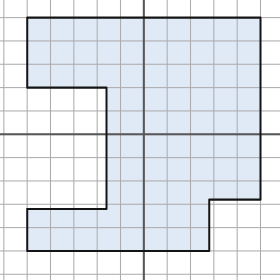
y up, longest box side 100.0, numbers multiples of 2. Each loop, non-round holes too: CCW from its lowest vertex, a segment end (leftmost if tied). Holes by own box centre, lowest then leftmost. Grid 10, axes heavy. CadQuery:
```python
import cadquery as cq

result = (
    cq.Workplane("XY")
    .moveTo(-50.0, -50.0)
    .lineTo(28.0, -50.0)
    .lineTo(28.0, -28.0)
    .lineTo(50.0, -28.0)
    .lineTo(50.0, 50.0)
    .lineTo(-50.0, 50.0)
    .lineTo(-50.0, 20.0)
    .lineTo(-16.0, 20.0)
    .lineTo(-16.0, -32.0)
    .lineTo(-50.0, -32.0)
    .close()
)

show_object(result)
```